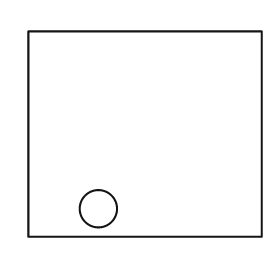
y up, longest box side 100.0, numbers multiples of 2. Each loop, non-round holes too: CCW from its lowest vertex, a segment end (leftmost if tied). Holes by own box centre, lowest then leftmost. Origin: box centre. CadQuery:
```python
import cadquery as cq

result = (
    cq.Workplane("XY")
    .moveTo(-50.0, -44.0)
    .lineTo(50.0, -44.0)
    .lineTo(50.0, 44.0)
    .lineTo(-50.0, 44.0)
    .close()
    .moveTo(-20.0, -32.0)
    .circle(8.0)
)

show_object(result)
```